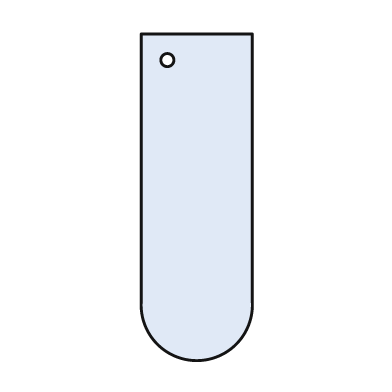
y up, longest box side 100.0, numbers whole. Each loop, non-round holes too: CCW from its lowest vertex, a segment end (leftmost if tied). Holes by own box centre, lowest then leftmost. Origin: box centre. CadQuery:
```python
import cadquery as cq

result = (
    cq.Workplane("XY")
    .moveTo(-17.0, -32.0)
    .threePointArc((0.0, -50.0), (17.0, -32.0))
    .lineTo(17.0, 50.0)
    .lineTo(-17.0, 50.0)
    .close()
    .moveTo(-9.0, 42.0)
    .circle(2.0)
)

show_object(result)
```